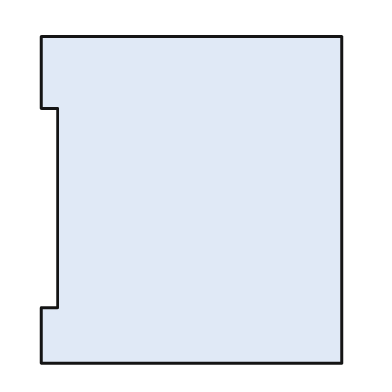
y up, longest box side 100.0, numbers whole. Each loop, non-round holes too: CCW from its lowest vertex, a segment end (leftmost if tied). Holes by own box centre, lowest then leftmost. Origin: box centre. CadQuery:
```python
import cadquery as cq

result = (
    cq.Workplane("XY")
    .moveTo(-46.0, -50.0)
    .lineTo(46.0, -50.0)
    .lineTo(46.0, 50.0)
    .lineTo(-46.0, 50.0)
    .lineTo(-46.0, 28.0)
    .lineTo(-41.0, 28.0)
    .lineTo(-41.0, -33.0)
    .lineTo(-46.0, -33.0)
    .close()
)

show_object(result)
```